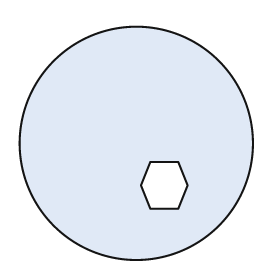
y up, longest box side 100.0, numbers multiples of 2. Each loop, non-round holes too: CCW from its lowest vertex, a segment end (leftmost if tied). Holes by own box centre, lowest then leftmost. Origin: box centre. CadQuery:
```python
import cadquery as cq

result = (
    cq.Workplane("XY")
    .moveTo(0.0, 0.0)
    .circle(50.0)
    .moveTo(6.0, -28.0)
    .lineTo(18.0, -28.0)
    .lineTo(22.0, -18.0)
    .lineTo(18.0, -8.0)
    .lineTo(6.0, -8.0)
    .lineTo(2.0, -18.0)
    .close()
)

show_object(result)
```